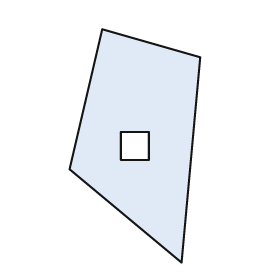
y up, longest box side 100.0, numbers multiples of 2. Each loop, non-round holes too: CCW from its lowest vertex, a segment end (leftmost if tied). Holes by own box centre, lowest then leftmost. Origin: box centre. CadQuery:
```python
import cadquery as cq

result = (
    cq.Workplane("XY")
    .moveTo(20.0, -50.0)
    .lineTo(28.0, 38.0)
    .lineTo(-14.0, 50.0)
    .lineTo(-28.0, -10.0)
    .close()
    .moveTo(-6.0, -6.0)
    .lineTo(6.0, -6.0)
    .lineTo(6.0, 6.0)
    .lineTo(-6.0, 6.0)
    .close()
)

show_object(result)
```